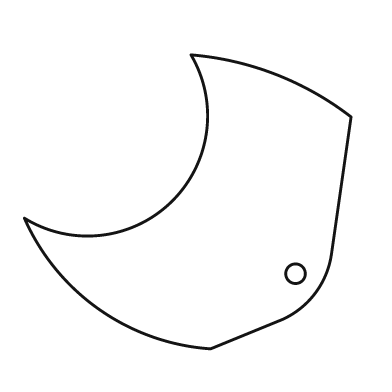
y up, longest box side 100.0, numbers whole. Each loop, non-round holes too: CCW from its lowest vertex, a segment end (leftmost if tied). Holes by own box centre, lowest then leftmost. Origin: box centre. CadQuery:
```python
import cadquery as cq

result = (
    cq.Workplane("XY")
    .moveTo(7.0, -45.0)
    .lineTo(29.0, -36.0)
    .threePointArc((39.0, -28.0), (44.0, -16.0))
    .lineTo(50.0, 26.0)
    .threePointArc((27.0, 39.0), (1.0, 45.0))
    .threePointArc((-5.0, 0.0), (-50.0, -5.0))
    .threePointArc((-27.0, -33.0), (7.0, -45.0))
    .close()
    .moveTo(33.0, -22.0)
    .circle(3.0)
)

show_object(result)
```